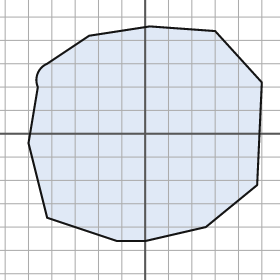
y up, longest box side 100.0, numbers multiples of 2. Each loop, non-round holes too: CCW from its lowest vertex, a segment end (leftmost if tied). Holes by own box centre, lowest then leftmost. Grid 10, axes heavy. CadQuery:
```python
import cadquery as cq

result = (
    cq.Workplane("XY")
    .moveTo(-12.0, -46.0)
    .lineTo(0.0, -46.0)
    .lineTo(26.0, -40.0)
    .lineTo(48.0, -22.0)
    .lineTo(50.0, 22.0)
    .lineTo(30.0, 44.0)
    .lineTo(2.0, 46.0)
    .lineTo(-24.0, 42.0)
    .lineTo(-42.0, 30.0)
    .threePointArc((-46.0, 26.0), (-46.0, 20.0))
    .lineTo(-50.0, -4.0)
    .lineTo(-42.0, -36.0)
    .close()
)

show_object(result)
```